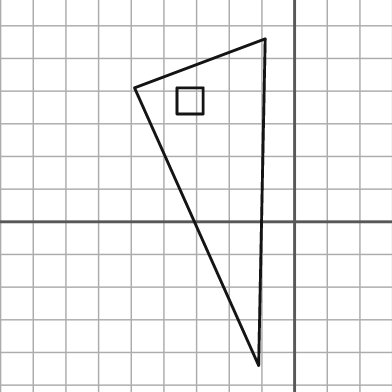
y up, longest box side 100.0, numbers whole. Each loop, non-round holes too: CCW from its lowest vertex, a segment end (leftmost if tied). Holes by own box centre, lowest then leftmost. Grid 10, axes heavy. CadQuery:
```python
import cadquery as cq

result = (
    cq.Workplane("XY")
    .moveTo(-11.0, -44.0)
    .lineTo(-9.0, 56.0)
    .lineTo(-49.0, 41.0)
    .close()
    .moveTo(-36.0, 33.0)
    .lineTo(-28.0, 33.0)
    .lineTo(-28.0, 41.0)
    .lineTo(-36.0, 41.0)
    .close()
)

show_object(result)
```